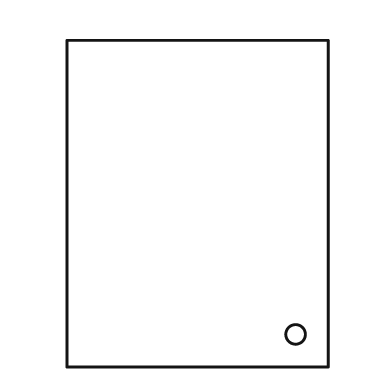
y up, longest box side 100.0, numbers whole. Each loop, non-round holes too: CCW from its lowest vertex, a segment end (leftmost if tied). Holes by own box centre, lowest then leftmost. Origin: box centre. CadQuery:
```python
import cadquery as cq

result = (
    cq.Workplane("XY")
    .moveTo(-40.0, -50.0)
    .lineTo(40.0, -50.0)
    .lineTo(40.0, 50.0)
    .lineTo(-40.0, 50.0)
    .close()
    .moveTo(30.0, -40.0)
    .circle(3.0)
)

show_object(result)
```